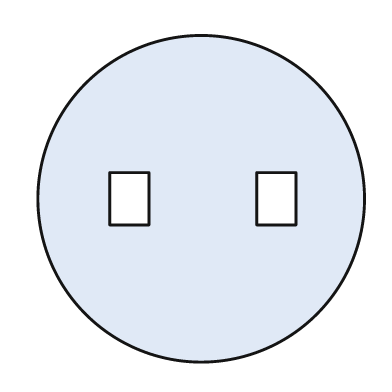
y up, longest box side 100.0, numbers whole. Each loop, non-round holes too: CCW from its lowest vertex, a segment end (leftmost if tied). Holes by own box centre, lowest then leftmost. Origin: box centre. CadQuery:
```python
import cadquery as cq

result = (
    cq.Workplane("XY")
    .moveTo(0.0, 0.0)
    .circle(50.0)
    .moveTo(-28.0, -8.0)
    .lineTo(-16.0, -8.0)
    .lineTo(-16.0, 8.0)
    .lineTo(-28.0, 8.0)
    .close()
    .moveTo(17.0, -8.0)
    .lineTo(29.0, -8.0)
    .lineTo(29.0, 8.0)
    .lineTo(17.0, 8.0)
    .close()
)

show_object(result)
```